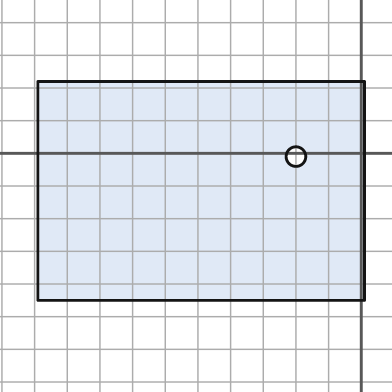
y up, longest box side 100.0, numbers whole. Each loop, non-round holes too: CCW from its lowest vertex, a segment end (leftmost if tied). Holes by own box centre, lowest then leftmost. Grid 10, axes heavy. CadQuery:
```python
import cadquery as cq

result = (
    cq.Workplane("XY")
    .moveTo(-99.0, -45.0)
    .lineTo(1.0, -45.0)
    .lineTo(1.0, 22.0)
    .lineTo(-99.0, 22.0)
    .close()
    .moveTo(-20.0, -1.0)
    .circle(3.0)
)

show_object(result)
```